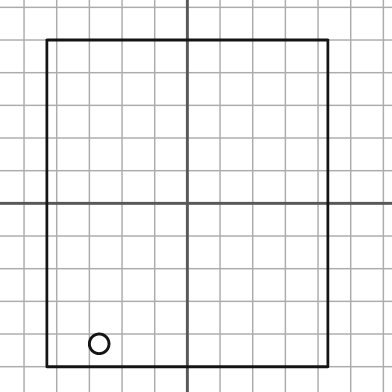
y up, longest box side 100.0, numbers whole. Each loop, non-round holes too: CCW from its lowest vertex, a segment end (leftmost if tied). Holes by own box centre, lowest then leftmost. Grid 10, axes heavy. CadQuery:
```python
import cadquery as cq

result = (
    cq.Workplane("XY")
    .moveTo(-43.0, -50.0)
    .lineTo(43.0, -50.0)
    .lineTo(43.0, 50.0)
    .lineTo(-43.0, 50.0)
    .close()
    .moveTo(-27.0, -43.0)
    .circle(3.0)
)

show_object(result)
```